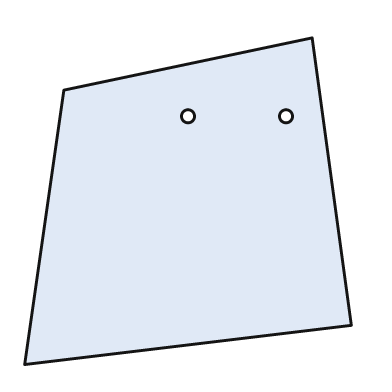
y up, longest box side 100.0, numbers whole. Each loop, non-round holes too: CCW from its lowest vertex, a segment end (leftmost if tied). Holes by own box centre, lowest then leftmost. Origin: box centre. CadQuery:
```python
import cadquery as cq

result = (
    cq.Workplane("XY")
    .moveTo(-50.0, -50.0)
    .lineTo(50.0, -38.0)
    .lineTo(38.0, 50.0)
    .lineTo(-38.0, 34.0)
    .close()
    .moveTo(0.0, 26.0)
    .circle(2.0)
    .moveTo(30.0, 26.0)
    .circle(2.0)
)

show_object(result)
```